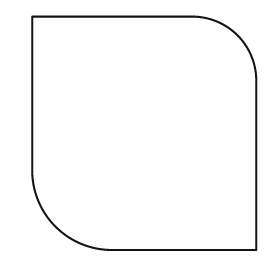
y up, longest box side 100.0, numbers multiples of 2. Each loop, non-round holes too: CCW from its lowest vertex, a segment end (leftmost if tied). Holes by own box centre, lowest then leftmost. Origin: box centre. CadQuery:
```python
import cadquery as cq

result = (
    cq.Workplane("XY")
    .moveTo(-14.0, -50.0)
    .lineTo(48.0, -50.0)
    .lineTo(48.0, 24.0)
    .threePointArc((40.0, 42.0), (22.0, 50.0))
    .lineTo(-48.0, 50.0)
    .lineTo(-48.0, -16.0)
    .threePointArc((-38.0, -40.0), (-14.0, -50.0))
    .close()
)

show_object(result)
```